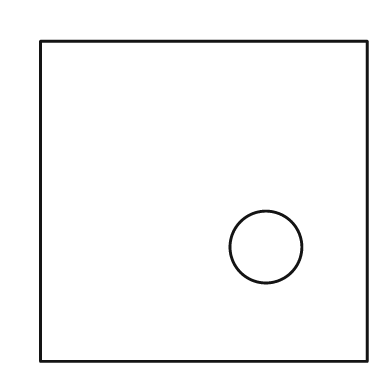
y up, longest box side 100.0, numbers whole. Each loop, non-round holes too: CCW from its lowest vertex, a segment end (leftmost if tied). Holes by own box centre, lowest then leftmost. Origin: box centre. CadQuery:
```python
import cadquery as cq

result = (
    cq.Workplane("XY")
    .moveTo(-50.0, -49.0)
    .lineTo(50.0, -49.0)
    .lineTo(50.0, 49.0)
    .lineTo(-50.0, 49.0)
    .close()
    .moveTo(19.0, -14.0)
    .circle(11.0)
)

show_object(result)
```